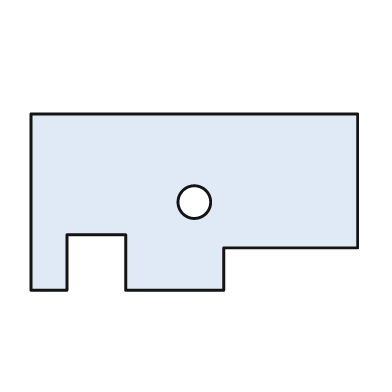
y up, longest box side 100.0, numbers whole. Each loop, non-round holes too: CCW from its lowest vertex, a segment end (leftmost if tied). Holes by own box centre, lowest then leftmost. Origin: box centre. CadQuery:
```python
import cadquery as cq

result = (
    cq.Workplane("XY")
    .moveTo(-50.0, -27.0)
    .lineTo(-39.0, -27.0)
    .lineTo(-39.0, -10.0)
    .lineTo(-21.0, -10.0)
    .lineTo(-21.0, -27.0)
    .lineTo(9.0, -27.0)
    .lineTo(9.0, -14.0)
    .lineTo(50.0, -14.0)
    .lineTo(50.0, 27.0)
    .lineTo(-50.0, 27.0)
    .close()
    .moveTo(0.0, 0.0)
    .circle(5.0)
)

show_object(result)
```